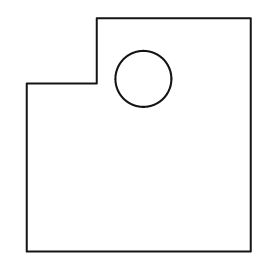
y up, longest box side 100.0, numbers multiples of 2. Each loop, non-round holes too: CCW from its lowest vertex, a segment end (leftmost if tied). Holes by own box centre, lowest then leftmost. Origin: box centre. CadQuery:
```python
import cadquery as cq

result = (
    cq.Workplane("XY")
    .moveTo(-48.0, -50.0)
    .lineTo(48.0, -50.0)
    .lineTo(48.0, 50.0)
    .lineTo(-18.0, 50.0)
    .lineTo(-18.0, 22.0)
    .lineTo(-48.0, 22.0)
    .close()
    .moveTo(2.0, 24.0)
    .circle(12.0)
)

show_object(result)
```